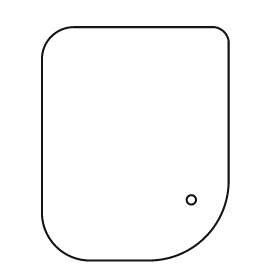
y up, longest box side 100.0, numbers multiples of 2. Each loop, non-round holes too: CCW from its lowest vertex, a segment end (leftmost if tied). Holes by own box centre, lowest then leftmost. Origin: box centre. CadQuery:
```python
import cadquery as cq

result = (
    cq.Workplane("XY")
    .moveTo(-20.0, -50.0)
    .lineTo(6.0, -50.0)
    .threePointArc((30.0, -40.0), (40.0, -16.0))
    .lineTo(40.0, 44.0)
    .threePointArc((38.0, 48.0), (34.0, 50.0))
    .lineTo(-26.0, 50.0)
    .threePointArc((-36.0, 46.0), (-40.0, 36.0))
    .lineTo(-40.0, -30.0)
    .threePointArc((-34.0, -44.0), (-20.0, -50.0))
    .close()
    .moveTo(24.0, -24.0)
    .circle(2.0)
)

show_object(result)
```